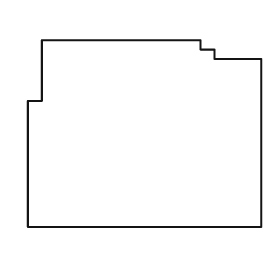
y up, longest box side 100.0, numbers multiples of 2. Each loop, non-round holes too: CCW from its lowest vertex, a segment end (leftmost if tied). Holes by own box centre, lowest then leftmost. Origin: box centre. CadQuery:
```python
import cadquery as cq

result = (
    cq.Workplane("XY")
    .moveTo(-50.0, -40.0)
    .lineTo(50.0, -40.0)
    .lineTo(50.0, 32.0)
    .lineTo(30.0, 32.0)
    .lineTo(30.0, 36.0)
    .lineTo(24.0, 36.0)
    .lineTo(24.0, 40.0)
    .lineTo(-44.0, 40.0)
    .lineTo(-44.0, 14.0)
    .lineTo(-50.0, 14.0)
    .close()
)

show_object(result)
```